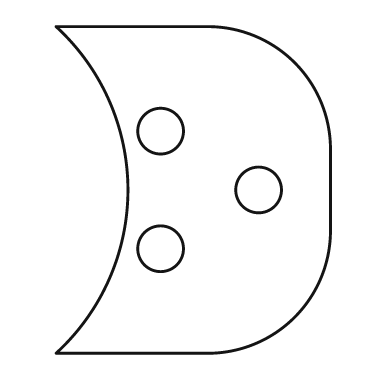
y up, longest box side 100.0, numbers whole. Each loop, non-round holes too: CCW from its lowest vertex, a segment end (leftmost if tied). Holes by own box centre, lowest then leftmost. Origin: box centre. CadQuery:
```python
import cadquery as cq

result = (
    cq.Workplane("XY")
    .moveTo(-42.0, -50.0)
    .lineTo(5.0, -50.0)
    .threePointArc((31.0, -39.0), (42.0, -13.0))
    .lineTo(42.0, 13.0)
    .threePointArc((31.0, 39.0), (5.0, 50.0))
    .lineTo(-42.0, 50.0)
    .threePointArc((-20.0, 0.0), (-42.0, -50.0))
    .close()
    .moveTo(-10.0, -18.0)
    .circle(7.0)
    .moveTo(20.0, 0.0)
    .circle(7.0)
    .moveTo(-10.0, 18.0)
    .circle(7.0)
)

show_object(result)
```